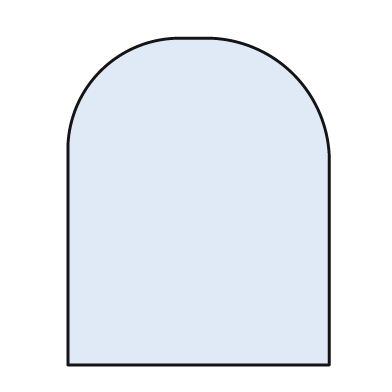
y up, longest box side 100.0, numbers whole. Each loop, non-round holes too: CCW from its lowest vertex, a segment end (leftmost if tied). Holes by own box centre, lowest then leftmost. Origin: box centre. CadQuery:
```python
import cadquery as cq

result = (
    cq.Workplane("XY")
    .moveTo(-40.0, -50.0)
    .lineTo(40.0, -50.0)
    .lineTo(40.0, 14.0)
    .threePointArc((29.0, 39.0), (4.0, 50.0))
    .lineTo(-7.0, 50.0)
    .threePointArc((-30.0, 40.0), (-40.0, 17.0))
    .close()
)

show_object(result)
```